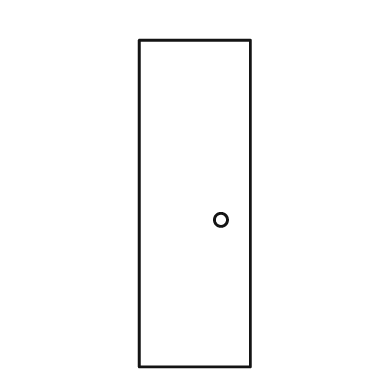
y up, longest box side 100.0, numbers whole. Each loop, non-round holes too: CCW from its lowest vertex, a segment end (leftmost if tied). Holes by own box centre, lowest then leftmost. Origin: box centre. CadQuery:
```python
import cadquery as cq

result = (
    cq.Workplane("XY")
    .moveTo(-17.0, -50.0)
    .lineTo(17.0, -50.0)
    .lineTo(17.0, 50.0)
    .lineTo(-17.0, 50.0)
    .close()
    .moveTo(8.0, -5.0)
    .circle(2.0)
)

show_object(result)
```